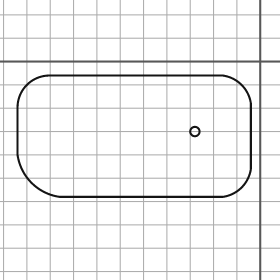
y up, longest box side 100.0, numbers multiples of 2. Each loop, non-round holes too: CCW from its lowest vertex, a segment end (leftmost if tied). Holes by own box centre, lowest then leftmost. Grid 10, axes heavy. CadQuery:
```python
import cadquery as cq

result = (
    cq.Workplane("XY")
    .moveTo(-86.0, -58.0)
    .lineTo(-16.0, -58.0)
    .threePointArc((-8.0, -54.0), (-4.0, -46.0))
    .lineTo(-4.0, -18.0)
    .threePointArc((-8.0, -10.0), (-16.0, -6.0))
    .lineTo(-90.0, -6.0)
    .threePointArc((-100.0, -10.0), (-104.0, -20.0))
    .lineTo(-104.0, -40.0)
    .threePointArc((-98.0, -52.0), (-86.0, -58.0))
    .close()
    .moveTo(-28.0, -30.0)
    .circle(2.0)
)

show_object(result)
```